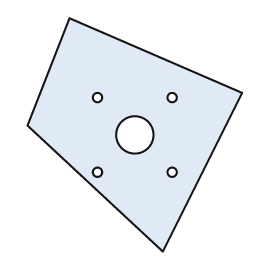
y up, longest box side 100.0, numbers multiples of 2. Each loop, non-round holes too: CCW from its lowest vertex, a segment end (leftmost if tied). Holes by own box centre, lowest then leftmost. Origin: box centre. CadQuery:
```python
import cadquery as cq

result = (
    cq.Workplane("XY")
    .moveTo(12.0, -50.0)
    .lineTo(46.0, 18.0)
    .lineTo(-28.0, 50.0)
    .lineTo(-46.0, 4.0)
    .close()
    .moveTo(-16.0, -16.0)
    .circle(2.0)
    .moveTo(16.0, -16.0)
    .circle(2.0)
    .moveTo(0.0, 0.0)
    .circle(8.0)
    .moveTo(-16.0, 16.0)
    .circle(2.0)
    .moveTo(16.0, 16.0)
    .circle(2.0)
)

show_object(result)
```